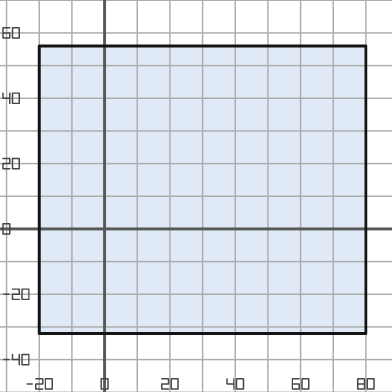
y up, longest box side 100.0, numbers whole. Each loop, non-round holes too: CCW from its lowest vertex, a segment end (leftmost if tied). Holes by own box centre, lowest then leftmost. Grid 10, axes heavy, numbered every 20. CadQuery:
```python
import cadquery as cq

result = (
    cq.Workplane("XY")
    .moveTo(-20.0, -32.0)
    .lineTo(80.0, -32.0)
    .lineTo(80.0, 56.0)
    .lineTo(-20.0, 56.0)
    .close()
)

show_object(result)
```